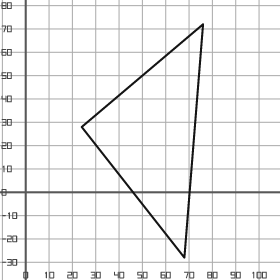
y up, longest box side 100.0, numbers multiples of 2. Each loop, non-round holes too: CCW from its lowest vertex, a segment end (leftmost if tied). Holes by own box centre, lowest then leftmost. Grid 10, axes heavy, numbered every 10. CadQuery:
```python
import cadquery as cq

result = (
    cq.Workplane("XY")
    .moveTo(68.0, -28.0)
    .lineTo(76.0, 72.0)
    .lineTo(24.0, 28.0)
    .close()
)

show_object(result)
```